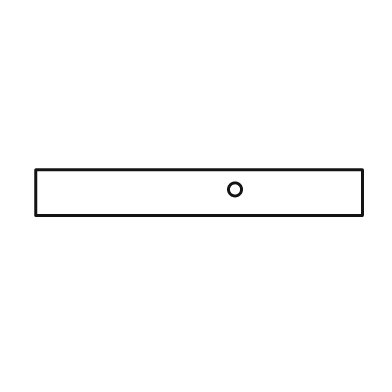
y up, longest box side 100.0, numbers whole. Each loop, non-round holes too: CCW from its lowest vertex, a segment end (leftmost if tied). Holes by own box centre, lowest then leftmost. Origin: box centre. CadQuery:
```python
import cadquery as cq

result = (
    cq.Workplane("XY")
    .moveTo(-50.0, -7.0)
    .lineTo(50.0, -7.0)
    .lineTo(50.0, 7.0)
    .lineTo(-50.0, 7.0)
    .close()
    .moveTo(11.0, 1.0)
    .circle(2.0)
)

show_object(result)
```